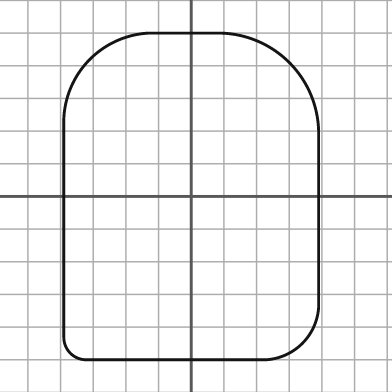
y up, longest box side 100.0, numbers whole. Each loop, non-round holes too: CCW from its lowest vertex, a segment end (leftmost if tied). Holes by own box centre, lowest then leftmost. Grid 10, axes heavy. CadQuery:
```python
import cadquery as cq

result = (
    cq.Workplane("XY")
    .moveTo(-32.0, -50.0)
    .lineTo(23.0, -50.0)
    .threePointArc((34.0, -45.0), (39.0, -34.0))
    .lineTo(39.0, 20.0)
    .threePointArc((30.0, 41.0), (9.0, 50.0))
    .lineTo(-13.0, 50.0)
    .threePointArc((-31.0, 42.0), (-39.0, 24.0))
    .lineTo(-39.0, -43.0)
    .threePointArc((-37.0, -48.0), (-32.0, -50.0))
    .close()
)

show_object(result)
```